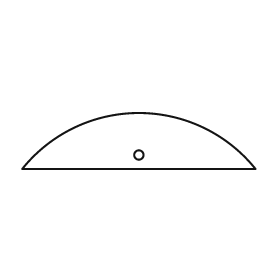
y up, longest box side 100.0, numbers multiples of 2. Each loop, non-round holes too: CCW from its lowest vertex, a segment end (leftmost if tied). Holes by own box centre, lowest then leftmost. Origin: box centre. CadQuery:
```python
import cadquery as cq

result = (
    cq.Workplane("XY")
    .moveTo(-50.0, -12.0)
    .lineTo(50.0, -12.0)
    .threePointArc((0.0, 12.0), (-50.0, -12.0))
    .close()
    .moveTo(0.0, -6.0)
    .circle(2.0)
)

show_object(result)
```